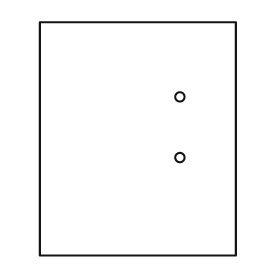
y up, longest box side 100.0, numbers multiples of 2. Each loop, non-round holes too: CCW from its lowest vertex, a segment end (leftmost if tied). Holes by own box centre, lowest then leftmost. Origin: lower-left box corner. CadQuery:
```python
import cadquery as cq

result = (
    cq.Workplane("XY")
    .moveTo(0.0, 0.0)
    .lineTo(84.0, 0.0)
    .lineTo(84.0, 100.0)
    .lineTo(0.0, 100.0)
    .close()
    .moveTo(60.0, 42.0)
    .circle(2.0)
    .moveTo(60.0, 68.0)
    .circle(2.0)
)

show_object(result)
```